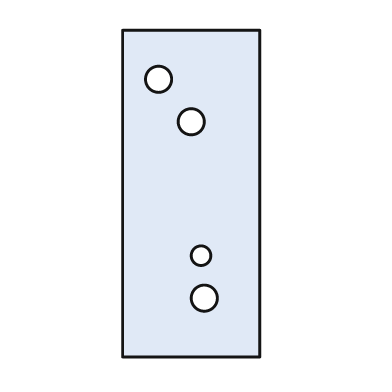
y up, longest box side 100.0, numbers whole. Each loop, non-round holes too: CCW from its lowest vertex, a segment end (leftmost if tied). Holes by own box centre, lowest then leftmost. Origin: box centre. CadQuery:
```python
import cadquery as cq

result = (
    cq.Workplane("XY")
    .moveTo(-21.0, -50.0)
    .lineTo(21.0, -50.0)
    .lineTo(21.0, 50.0)
    .lineTo(-21.0, 50.0)
    .close()
    .moveTo(4.0, -32.0)
    .circle(4.0)
    .moveTo(3.0, -19.0)
    .circle(3.0)
    .moveTo(0.0, 22.0)
    .circle(4.0)
    .moveTo(-10.0, 35.0)
    .circle(4.0)
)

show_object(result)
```